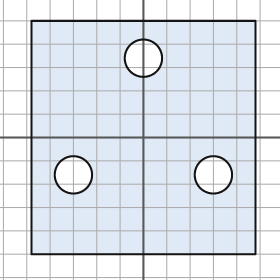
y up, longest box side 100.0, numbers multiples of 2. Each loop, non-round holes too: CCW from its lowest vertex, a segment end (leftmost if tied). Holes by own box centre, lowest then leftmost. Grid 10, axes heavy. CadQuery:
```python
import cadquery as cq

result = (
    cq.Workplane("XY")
    .moveTo(-48.0, -50.0)
    .lineTo(48.0, -50.0)
    .lineTo(48.0, 50.0)
    .lineTo(-48.0, 50.0)
    .close()
    .moveTo(-30.0, -16.0)
    .circle(8.0)
    .moveTo(30.0, -16.0)
    .circle(8.0)
    .moveTo(0.0, 34.0)
    .circle(8.0)
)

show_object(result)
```